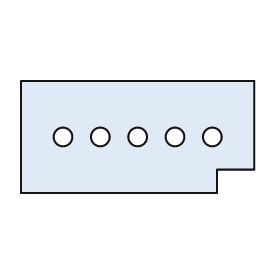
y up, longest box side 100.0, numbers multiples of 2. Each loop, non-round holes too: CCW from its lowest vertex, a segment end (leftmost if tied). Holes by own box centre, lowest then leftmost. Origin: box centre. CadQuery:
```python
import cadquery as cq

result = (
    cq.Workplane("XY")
    .moveTo(-50.0, -24.0)
    .lineTo(34.0, -24.0)
    .lineTo(34.0, -14.0)
    .lineTo(50.0, -14.0)
    .lineTo(50.0, 24.0)
    .lineTo(-50.0, 24.0)
    .close()
    .moveTo(-32.0, 0.0)
    .circle(4.0)
    .moveTo(-16.0, 0.0)
    .circle(4.0)
    .moveTo(0.0, 0.0)
    .circle(4.0)
    .moveTo(16.0, 0.0)
    .circle(4.0)
    .moveTo(32.0, 0.0)
    .circle(4.0)
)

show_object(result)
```